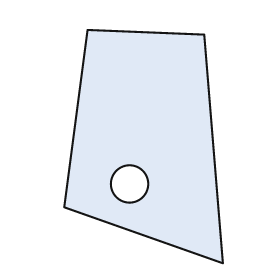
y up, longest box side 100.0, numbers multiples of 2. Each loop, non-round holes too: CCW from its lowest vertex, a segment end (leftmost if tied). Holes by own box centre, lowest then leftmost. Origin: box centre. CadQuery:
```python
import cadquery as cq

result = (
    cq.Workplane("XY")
    .moveTo(34.0, -50.0)
    .lineTo(26.0, 48.0)
    .lineTo(-24.0, 50.0)
    .lineTo(-34.0, -26.0)
    .close()
    .moveTo(-6.0, -16.0)
    .circle(8.0)
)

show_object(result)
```